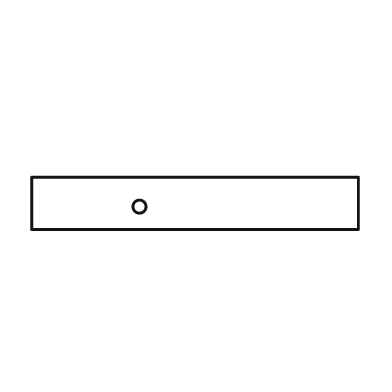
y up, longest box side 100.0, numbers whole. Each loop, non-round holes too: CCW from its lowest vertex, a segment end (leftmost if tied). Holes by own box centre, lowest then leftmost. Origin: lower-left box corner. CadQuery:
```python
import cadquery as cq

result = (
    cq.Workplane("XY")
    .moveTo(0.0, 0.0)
    .lineTo(100.0, 0.0)
    .lineTo(100.0, 16.0)
    .lineTo(0.0, 16.0)
    .close()
    .moveTo(33.0, 7.0)
    .circle(2.0)
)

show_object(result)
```